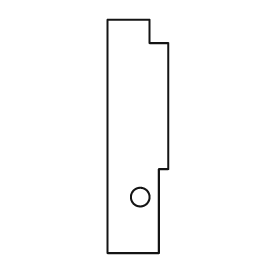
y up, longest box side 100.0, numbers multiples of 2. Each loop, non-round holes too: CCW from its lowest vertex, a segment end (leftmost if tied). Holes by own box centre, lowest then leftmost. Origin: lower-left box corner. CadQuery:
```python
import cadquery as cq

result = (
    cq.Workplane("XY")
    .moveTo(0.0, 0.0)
    .lineTo(22.0, 0.0)
    .lineTo(22.0, 36.0)
    .lineTo(26.0, 36.0)
    .lineTo(26.0, 90.0)
    .lineTo(18.0, 90.0)
    .lineTo(18.0, 100.0)
    .lineTo(0.0, 100.0)
    .close()
    .moveTo(14.0, 24.0)
    .circle(4.0)
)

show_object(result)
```